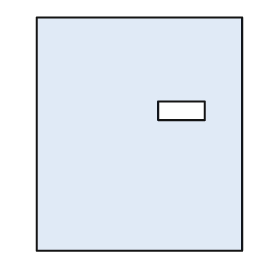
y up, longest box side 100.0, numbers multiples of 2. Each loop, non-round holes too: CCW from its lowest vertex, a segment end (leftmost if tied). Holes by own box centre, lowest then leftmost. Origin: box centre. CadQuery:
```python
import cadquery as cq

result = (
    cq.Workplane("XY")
    .moveTo(-44.0, -50.0)
    .lineTo(44.0, -50.0)
    .lineTo(44.0, 50.0)
    .lineTo(-44.0, 50.0)
    .close()
    .moveTo(8.0, 6.0)
    .lineTo(28.0, 6.0)
    .lineTo(28.0, 14.0)
    .lineTo(8.0, 14.0)
    .close()
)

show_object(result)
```